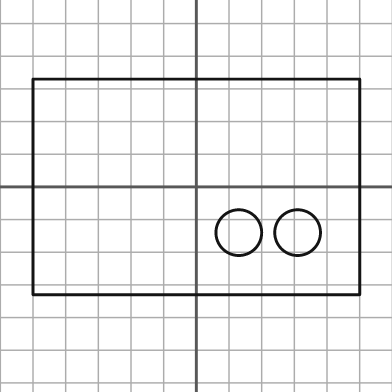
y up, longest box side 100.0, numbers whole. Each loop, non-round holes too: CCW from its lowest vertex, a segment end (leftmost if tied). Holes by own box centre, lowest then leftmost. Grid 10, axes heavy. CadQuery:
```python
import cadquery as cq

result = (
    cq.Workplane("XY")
    .moveTo(-50.0, -33.0)
    .lineTo(50.0, -33.0)
    .lineTo(50.0, 33.0)
    .lineTo(-50.0, 33.0)
    .close()
    .moveTo(13.0, -14.0)
    .circle(7.0)
    .moveTo(31.0, -14.0)
    .circle(7.0)
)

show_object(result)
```